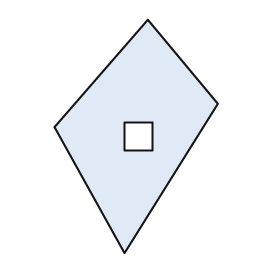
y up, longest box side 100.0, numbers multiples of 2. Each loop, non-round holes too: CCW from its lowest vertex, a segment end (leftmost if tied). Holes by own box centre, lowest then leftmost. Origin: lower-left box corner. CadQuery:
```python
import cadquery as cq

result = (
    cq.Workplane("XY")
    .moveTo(30.0, 0.0)
    .lineTo(70.0, 64.0)
    .lineTo(40.0, 100.0)
    .lineTo(0.0, 54.0)
    .close()
    .moveTo(30.0, 44.0)
    .lineTo(42.0, 44.0)
    .lineTo(42.0, 56.0)
    .lineTo(30.0, 56.0)
    .close()
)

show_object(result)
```